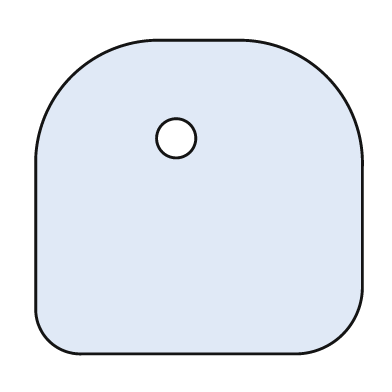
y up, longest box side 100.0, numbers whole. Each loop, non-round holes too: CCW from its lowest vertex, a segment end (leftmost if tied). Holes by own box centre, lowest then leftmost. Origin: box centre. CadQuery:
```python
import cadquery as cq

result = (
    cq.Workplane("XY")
    .moveTo(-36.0, -48.0)
    .lineTo(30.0, -48.0)
    .threePointArc((44.0, -42.0), (50.0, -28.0))
    .lineTo(50.0, 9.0)
    .threePointArc((39.0, 37.0), (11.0, 48.0))
    .lineTo(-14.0, 48.0)
    .threePointArc((-39.0, 37.0), (-50.0, 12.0))
    .lineTo(-50.0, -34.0)
    .threePointArc((-46.0, -44.0), (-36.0, -48.0))
    .close()
    .moveTo(-7.0, 18.0)
    .circle(6.0)
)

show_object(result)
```